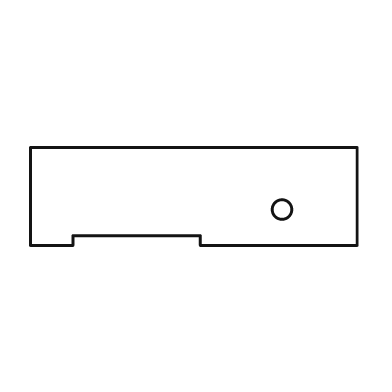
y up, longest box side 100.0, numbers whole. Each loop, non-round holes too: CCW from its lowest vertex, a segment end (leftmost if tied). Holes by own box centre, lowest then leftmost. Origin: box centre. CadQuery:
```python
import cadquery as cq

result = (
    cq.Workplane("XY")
    .moveTo(-50.0, -15.0)
    .lineTo(-37.0, -15.0)
    .lineTo(-37.0, -12.0)
    .lineTo(2.0, -12.0)
    .lineTo(2.0, -15.0)
    .lineTo(50.0, -15.0)
    .lineTo(50.0, 15.0)
    .lineTo(-50.0, 15.0)
    .close()
    .moveTo(27.0, -4.0)
    .circle(3.0)
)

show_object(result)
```